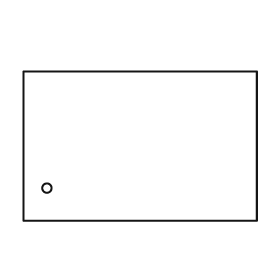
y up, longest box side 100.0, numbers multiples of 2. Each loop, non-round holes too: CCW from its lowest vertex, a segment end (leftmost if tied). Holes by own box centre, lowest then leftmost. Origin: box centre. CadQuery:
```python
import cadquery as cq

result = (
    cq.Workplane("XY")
    .moveTo(-50.0, -32.0)
    .lineTo(50.0, -32.0)
    .lineTo(50.0, 32.0)
    .lineTo(-50.0, 32.0)
    .close()
    .moveTo(-40.0, -18.0)
    .circle(2.0)
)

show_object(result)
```